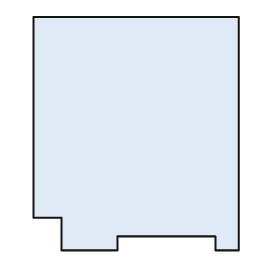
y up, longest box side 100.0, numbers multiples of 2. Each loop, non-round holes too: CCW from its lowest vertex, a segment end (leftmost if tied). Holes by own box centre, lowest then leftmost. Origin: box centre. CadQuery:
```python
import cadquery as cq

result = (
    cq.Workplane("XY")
    .moveTo(-32.0, -50.0)
    .lineTo(-8.0, -50.0)
    .lineTo(-8.0, -44.0)
    .lineTo(34.0, -44.0)
    .lineTo(34.0, -50.0)
    .lineTo(44.0, -50.0)
    .lineTo(44.0, 50.0)
    .lineTo(-44.0, 50.0)
    .lineTo(-44.0, -36.0)
    .lineTo(-32.0, -36.0)
    .close()
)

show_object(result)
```